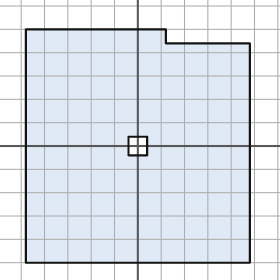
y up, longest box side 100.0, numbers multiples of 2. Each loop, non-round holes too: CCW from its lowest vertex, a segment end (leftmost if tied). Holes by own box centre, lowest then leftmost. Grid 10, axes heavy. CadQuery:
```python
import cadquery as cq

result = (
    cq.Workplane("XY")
    .moveTo(-48.0, -50.0)
    .lineTo(48.0, -50.0)
    .lineTo(48.0, 44.0)
    .lineTo(12.0, 44.0)
    .lineTo(12.0, 50.0)
    .lineTo(-48.0, 50.0)
    .close()
    .moveTo(-4.0, -4.0)
    .lineTo(4.0, -4.0)
    .lineTo(4.0, 4.0)
    .lineTo(-4.0, 4.0)
    .close()
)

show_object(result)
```